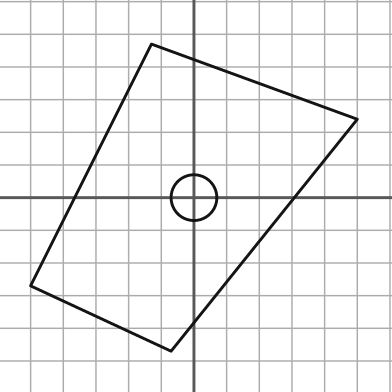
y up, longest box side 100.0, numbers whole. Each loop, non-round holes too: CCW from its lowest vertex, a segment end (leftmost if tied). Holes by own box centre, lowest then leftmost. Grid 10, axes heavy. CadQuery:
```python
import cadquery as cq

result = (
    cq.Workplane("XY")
    .moveTo(-7.0, -47.0)
    .lineTo(50.0, 24.0)
    .lineTo(-13.0, 47.0)
    .lineTo(-50.0, -27.0)
    .close()
    .moveTo(0.0, 0.0)
    .circle(7.0)
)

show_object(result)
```